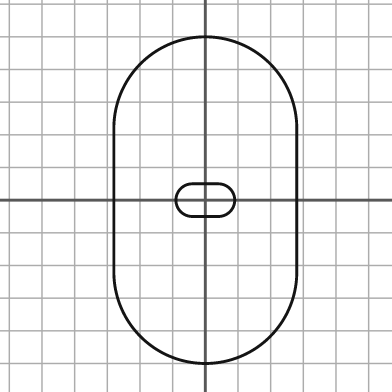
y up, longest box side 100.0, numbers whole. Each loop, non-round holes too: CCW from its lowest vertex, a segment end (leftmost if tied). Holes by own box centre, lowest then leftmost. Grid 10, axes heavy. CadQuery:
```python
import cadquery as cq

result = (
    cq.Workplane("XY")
    .moveTo(-28.0, -22.0)
    .threePointArc((0.0, -50.0), (28.0, -22.0))
    .lineTo(28.0, 22.0)
    .threePointArc((0.0, 50.0), (-28.0, 22.0))
    .close()
    .moveTo(-4.0, -5.0)
    .lineTo(4.0, -5.0)
    .threePointArc((9.0, 0.0), (4.0, 5.0))
    .lineTo(-4.0, 5.0)
    .threePointArc((-9.0, 0.0), (-4.0, -5.0))
    .close()
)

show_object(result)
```